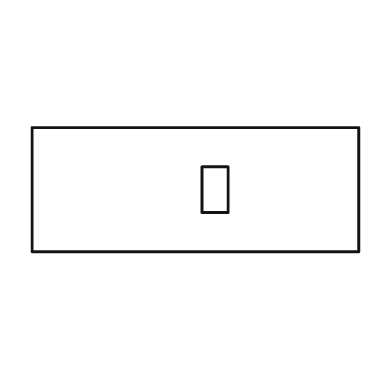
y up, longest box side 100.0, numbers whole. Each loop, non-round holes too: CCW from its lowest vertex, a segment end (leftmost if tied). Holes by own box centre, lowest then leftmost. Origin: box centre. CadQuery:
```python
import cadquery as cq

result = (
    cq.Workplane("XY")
    .moveTo(-50.0, -19.0)
    .lineTo(50.0, -19.0)
    .lineTo(50.0, 19.0)
    .lineTo(-50.0, 19.0)
    .close()
    .moveTo(2.0, -7.0)
    .lineTo(10.0, -7.0)
    .lineTo(10.0, 7.0)
    .lineTo(2.0, 7.0)
    .close()
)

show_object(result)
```